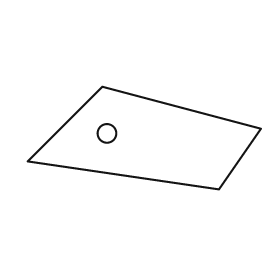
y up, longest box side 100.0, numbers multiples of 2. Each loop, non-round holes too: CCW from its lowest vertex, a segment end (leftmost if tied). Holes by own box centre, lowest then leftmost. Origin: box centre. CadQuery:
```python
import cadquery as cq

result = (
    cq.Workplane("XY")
    .moveTo(32.0, -22.0)
    .lineTo(50.0, 4.0)
    .lineTo(-18.0, 22.0)
    .lineTo(-50.0, -10.0)
    .close()
    .moveTo(-16.0, 2.0)
    .circle(4.0)
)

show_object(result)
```